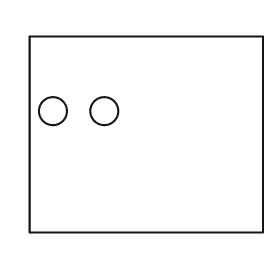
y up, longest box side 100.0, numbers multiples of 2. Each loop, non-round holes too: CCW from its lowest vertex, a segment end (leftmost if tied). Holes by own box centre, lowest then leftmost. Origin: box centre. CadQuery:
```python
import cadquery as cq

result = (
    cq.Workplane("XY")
    .moveTo(-50.0, -42.0)
    .lineTo(50.0, -42.0)
    .lineTo(50.0, 42.0)
    .lineTo(-50.0, 42.0)
    .close()
    .moveTo(-40.0, 10.0)
    .circle(6.0)
    .moveTo(-18.0, 10.0)
    .circle(6.0)
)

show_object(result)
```